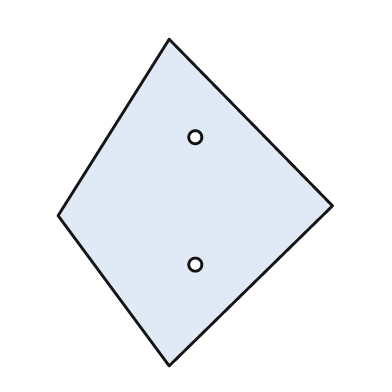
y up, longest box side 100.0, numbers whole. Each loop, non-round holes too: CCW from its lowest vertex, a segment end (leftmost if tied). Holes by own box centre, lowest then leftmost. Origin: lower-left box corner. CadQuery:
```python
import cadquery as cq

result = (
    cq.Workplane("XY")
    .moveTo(34.0, 0.0)
    .lineTo(84.0, 49.0)
    .lineTo(34.0, 100.0)
    .lineTo(0.0, 46.0)
    .close()
    .moveTo(42.0, 31.0)
    .circle(2.0)
    .moveTo(42.0, 70.0)
    .circle(2.0)
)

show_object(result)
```